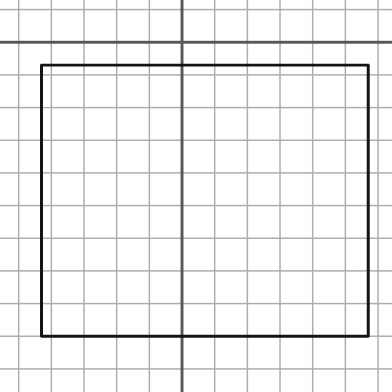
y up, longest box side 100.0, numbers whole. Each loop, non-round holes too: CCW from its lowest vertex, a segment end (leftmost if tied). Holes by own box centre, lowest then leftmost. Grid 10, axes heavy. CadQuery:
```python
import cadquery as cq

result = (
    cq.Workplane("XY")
    .moveTo(-43.0, -90.0)
    .lineTo(57.0, -90.0)
    .lineTo(57.0, -7.0)
    .lineTo(-43.0, -7.0)
    .close()
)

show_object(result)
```